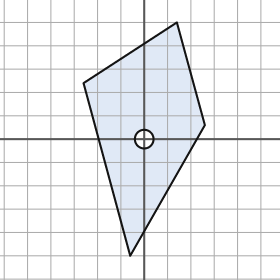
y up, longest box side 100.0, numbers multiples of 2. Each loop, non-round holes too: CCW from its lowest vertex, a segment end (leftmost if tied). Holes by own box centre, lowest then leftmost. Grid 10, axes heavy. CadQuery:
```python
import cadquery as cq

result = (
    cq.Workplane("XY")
    .moveTo(-6.0, -50.0)
    .lineTo(26.0, 6.0)
    .lineTo(14.0, 50.0)
    .lineTo(-26.0, 24.0)
    .close()
    .moveTo(0.0, 0.0)
    .circle(4.0)
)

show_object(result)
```